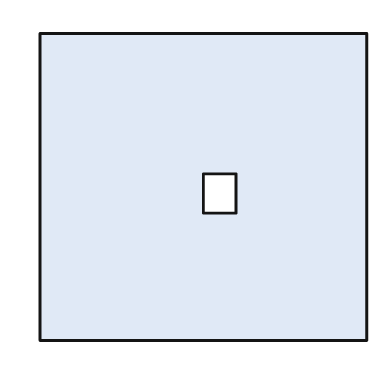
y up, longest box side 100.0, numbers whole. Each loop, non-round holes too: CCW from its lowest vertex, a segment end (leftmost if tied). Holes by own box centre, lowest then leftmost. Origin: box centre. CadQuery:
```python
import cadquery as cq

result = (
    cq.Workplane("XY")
    .moveTo(-50.0, -47.0)
    .lineTo(50.0, -47.0)
    .lineTo(50.0, 47.0)
    .lineTo(-50.0, 47.0)
    .close()
    .moveTo(0.0, -8.0)
    .lineTo(10.0, -8.0)
    .lineTo(10.0, 4.0)
    .lineTo(0.0, 4.0)
    .close()
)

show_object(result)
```